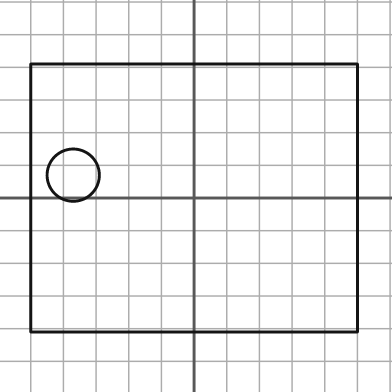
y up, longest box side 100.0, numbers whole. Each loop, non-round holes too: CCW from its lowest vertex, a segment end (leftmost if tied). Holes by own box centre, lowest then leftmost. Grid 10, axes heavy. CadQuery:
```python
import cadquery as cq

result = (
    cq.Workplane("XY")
    .moveTo(-50.0, -41.0)
    .lineTo(50.0, -41.0)
    .lineTo(50.0, 41.0)
    .lineTo(-50.0, 41.0)
    .close()
    .moveTo(-37.0, 7.0)
    .circle(8.0)
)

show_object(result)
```